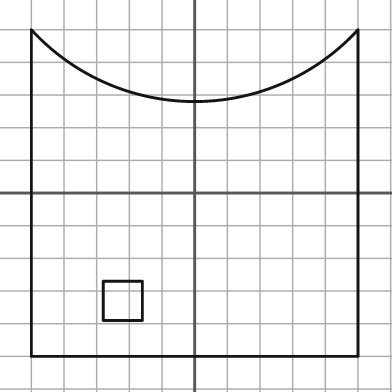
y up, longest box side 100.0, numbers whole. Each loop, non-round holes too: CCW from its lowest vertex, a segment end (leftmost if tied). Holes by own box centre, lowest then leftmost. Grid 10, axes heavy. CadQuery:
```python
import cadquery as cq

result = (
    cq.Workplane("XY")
    .moveTo(-50.0, -50.0)
    .lineTo(50.0, -50.0)
    .lineTo(50.0, 50.0)
    .threePointArc((0.0, 28.0), (-50.0, 50.0))
    .close()
    .moveTo(-28.0, -39.0)
    .lineTo(-16.0, -39.0)
    .lineTo(-16.0, -27.0)
    .lineTo(-28.0, -27.0)
    .close()
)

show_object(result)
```